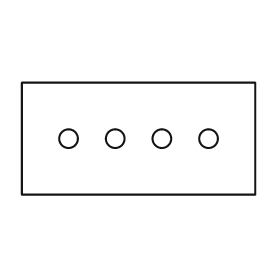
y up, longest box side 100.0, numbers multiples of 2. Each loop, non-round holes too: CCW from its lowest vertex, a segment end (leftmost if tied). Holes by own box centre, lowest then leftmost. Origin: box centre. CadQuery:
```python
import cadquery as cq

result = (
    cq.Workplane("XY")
    .moveTo(-50.0, -24.0)
    .lineTo(50.0, -24.0)
    .lineTo(50.0, 24.0)
    .lineTo(-50.0, 24.0)
    .close()
    .moveTo(-30.0, 0.0)
    .circle(4.0)
    .moveTo(-10.0, 0.0)
    .circle(4.0)
    .moveTo(10.0, 0.0)
    .circle(4.0)
    .moveTo(30.0, 0.0)
    .circle(4.0)
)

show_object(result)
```